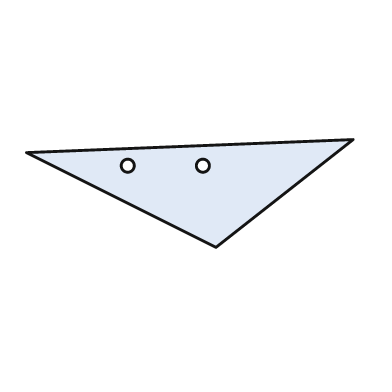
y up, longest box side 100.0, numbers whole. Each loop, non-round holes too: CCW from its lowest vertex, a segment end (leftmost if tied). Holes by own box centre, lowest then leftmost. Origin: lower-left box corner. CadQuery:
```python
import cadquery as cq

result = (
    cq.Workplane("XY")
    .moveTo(58.0, 0.0)
    .lineTo(100.0, 33.0)
    .lineTo(0.0, 29.0)
    .close()
    .moveTo(31.0, 25.0)
    .circle(2.0)
    .moveTo(54.0, 25.0)
    .circle(2.0)
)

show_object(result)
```